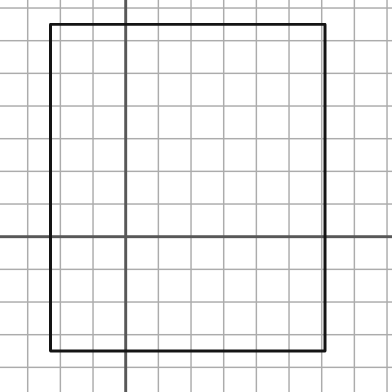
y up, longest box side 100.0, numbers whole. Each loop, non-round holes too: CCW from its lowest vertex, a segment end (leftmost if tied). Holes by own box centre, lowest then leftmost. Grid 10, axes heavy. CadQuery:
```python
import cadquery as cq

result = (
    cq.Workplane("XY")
    .moveTo(-23.0, -35.0)
    .lineTo(61.0, -35.0)
    .lineTo(61.0, 65.0)
    .lineTo(-23.0, 65.0)
    .close()
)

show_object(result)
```